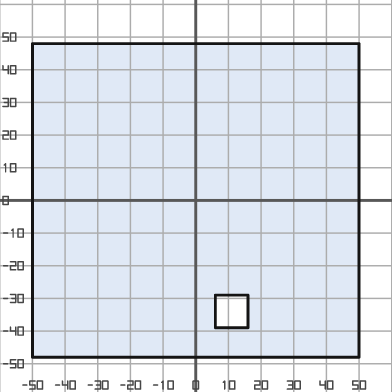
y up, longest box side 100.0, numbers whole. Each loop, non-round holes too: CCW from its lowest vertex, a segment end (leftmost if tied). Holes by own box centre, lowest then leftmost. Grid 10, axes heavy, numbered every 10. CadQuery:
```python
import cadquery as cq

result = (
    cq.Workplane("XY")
    .moveTo(-50.0, -48.0)
    .lineTo(50.0, -48.0)
    .lineTo(50.0, 48.0)
    .lineTo(-50.0, 48.0)
    .close()
    .moveTo(6.0, -39.0)
    .lineTo(16.0, -39.0)
    .lineTo(16.0, -29.0)
    .lineTo(6.0, -29.0)
    .close()
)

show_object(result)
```